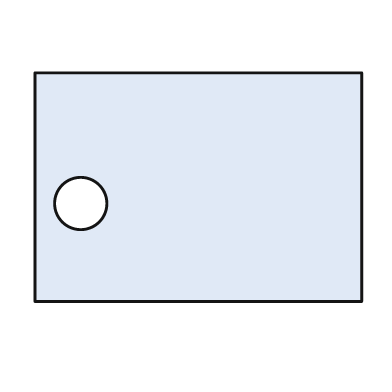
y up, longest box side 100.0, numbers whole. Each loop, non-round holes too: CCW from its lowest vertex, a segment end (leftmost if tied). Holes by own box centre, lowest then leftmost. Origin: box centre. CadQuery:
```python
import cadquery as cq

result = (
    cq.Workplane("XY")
    .moveTo(-50.0, -35.0)
    .lineTo(50.0, -35.0)
    .lineTo(50.0, 35.0)
    .lineTo(-50.0, 35.0)
    .close()
    .moveTo(-36.0, -5.0)
    .circle(8.0)
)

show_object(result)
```